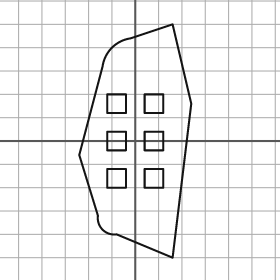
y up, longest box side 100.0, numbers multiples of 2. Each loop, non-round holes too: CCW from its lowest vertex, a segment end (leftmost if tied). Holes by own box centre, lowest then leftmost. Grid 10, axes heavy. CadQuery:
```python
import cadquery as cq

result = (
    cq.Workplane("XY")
    .moveTo(16.0, -50.0)
    .lineTo(24.0, 16.0)
    .lineTo(16.0, 50.0)
    .lineTo(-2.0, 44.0)
    .threePointArc((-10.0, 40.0), (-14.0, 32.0))
    .lineTo(-24.0, -6.0)
    .lineTo(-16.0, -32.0)
    .threePointArc((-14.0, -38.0), (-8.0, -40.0))
    .close()
    .moveTo(-12.0, -20.0)
    .lineTo(-4.0, -20.0)
    .lineTo(-4.0, -12.0)
    .lineTo(-12.0, -12.0)
    .close()
    .moveTo(4.0, -20.0)
    .lineTo(12.0, -20.0)
    .lineTo(12.0, -12.0)
    .lineTo(4.0, -12.0)
    .close()
    .moveTo(-12.0, -4.0)
    .lineTo(-4.0, -4.0)
    .lineTo(-4.0, 4.0)
    .lineTo(-12.0, 4.0)
    .close()
    .moveTo(4.0, -4.0)
    .lineTo(12.0, -4.0)
    .lineTo(12.0, 4.0)
    .lineTo(4.0, 4.0)
    .close()
    .moveTo(-12.0, 12.0)
    .lineTo(-4.0, 12.0)
    .lineTo(-4.0, 20.0)
    .lineTo(-12.0, 20.0)
    .close()
    .moveTo(4.0, 12.0)
    .lineTo(12.0, 12.0)
    .lineTo(12.0, 20.0)
    .lineTo(4.0, 20.0)
    .close()
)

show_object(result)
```